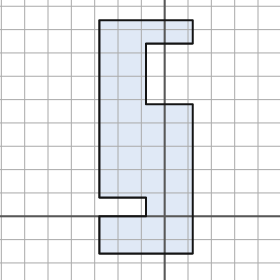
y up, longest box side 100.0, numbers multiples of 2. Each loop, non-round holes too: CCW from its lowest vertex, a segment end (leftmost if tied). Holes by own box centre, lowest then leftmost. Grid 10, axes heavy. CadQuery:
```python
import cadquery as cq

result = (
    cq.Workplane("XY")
    .moveTo(-28.0, -16.0)
    .lineTo(12.0, -16.0)
    .lineTo(12.0, 48.0)
    .lineTo(-8.0, 48.0)
    .lineTo(-8.0, 74.0)
    .lineTo(12.0, 74.0)
    .lineTo(12.0, 84.0)
    .lineTo(-28.0, 84.0)
    .lineTo(-28.0, 8.0)
    .lineTo(-8.0, 8.0)
    .lineTo(-8.0, 0.0)
    .lineTo(-28.0, 0.0)
    .close()
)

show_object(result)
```